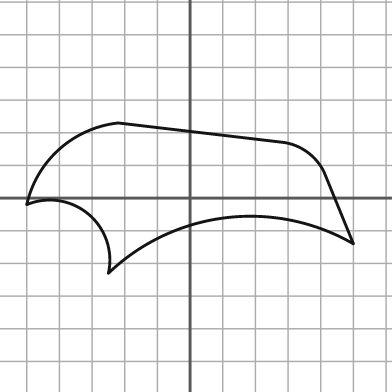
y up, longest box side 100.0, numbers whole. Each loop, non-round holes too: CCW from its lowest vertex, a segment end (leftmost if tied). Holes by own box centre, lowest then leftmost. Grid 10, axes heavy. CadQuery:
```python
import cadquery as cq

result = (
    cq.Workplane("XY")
    .moveTo(-25.0, -23.0)
    .threePointArc((11.0, -6.0), (50.0, -14.0))
    .lineTo(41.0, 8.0)
    .threePointArc((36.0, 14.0), (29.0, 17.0))
    .lineTo(-22.0, 23.0)
    .threePointArc((-40.0, 15.0), (-50.0, -2.0))
    .threePointArc((-31.0, -5.0), (-25.0, -23.0))
    .close()
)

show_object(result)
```